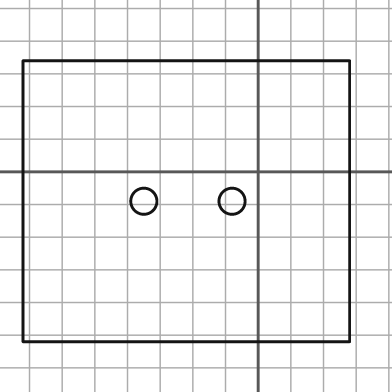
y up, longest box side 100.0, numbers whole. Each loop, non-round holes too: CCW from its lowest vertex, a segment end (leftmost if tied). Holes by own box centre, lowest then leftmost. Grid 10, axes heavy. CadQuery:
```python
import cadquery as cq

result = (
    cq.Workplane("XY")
    .moveTo(-72.0, -52.0)
    .lineTo(28.0, -52.0)
    .lineTo(28.0, 34.0)
    .lineTo(-72.0, 34.0)
    .close()
    .moveTo(-35.0, -9.0)
    .circle(4.0)
    .moveTo(-8.0, -9.0)
    .circle(4.0)
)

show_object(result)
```